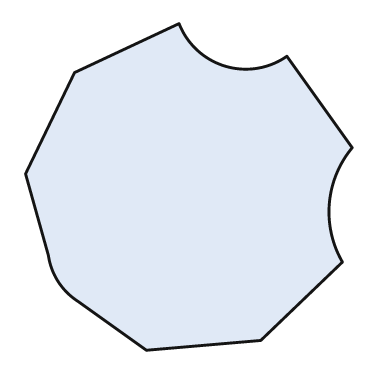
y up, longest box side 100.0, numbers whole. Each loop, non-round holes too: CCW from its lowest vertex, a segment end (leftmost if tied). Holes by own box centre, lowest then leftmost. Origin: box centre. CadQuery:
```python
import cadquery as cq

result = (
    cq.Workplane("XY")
    .moveTo(-13.0, -50.0)
    .lineTo(22.0, -47.0)
    .lineTo(47.0, -23.0)
    .threePointArc((43.0, -5.0), (50.0, 12.0))
    .lineTo(30.0, 40.0)
    .threePointArc((11.0, 37.0), (-3.0, 50.0))
    .lineTo(-35.0, 35.0)
    .lineTo(-50.0, 4.0)
    .lineTo(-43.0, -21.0)
    .threePointArc((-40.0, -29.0), (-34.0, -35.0))
    .close()
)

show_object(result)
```